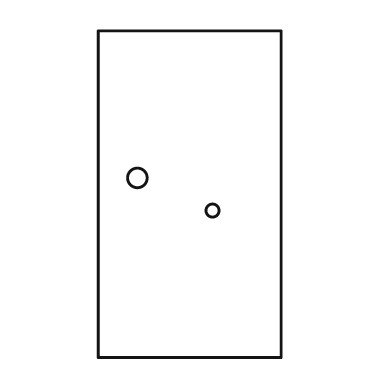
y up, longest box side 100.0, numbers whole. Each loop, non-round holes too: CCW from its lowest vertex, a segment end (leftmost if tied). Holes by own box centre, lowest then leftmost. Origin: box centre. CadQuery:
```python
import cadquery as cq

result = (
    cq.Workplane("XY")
    .moveTo(-28.0, -50.0)
    .lineTo(28.0, -50.0)
    .lineTo(28.0, 50.0)
    .lineTo(-28.0, 50.0)
    .close()
    .moveTo(7.0, -5.0)
    .circle(2.0)
    .moveTo(-16.0, 5.0)
    .circle(3.0)
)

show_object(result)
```